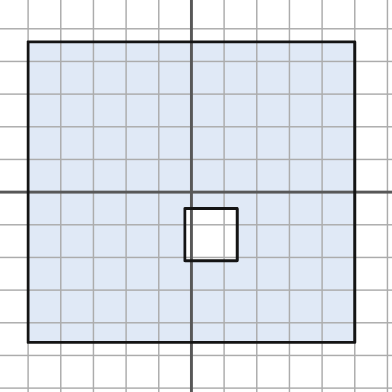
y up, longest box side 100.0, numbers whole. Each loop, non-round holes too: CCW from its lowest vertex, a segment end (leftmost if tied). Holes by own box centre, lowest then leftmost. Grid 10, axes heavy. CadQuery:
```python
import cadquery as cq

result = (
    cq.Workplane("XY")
    .moveTo(-50.0, -46.0)
    .lineTo(50.0, -46.0)
    .lineTo(50.0, 46.0)
    .lineTo(-50.0, 46.0)
    .close()
    .moveTo(-2.0, -21.0)
    .lineTo(14.0, -21.0)
    .lineTo(14.0, -5.0)
    .lineTo(-2.0, -5.0)
    .close()
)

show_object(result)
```